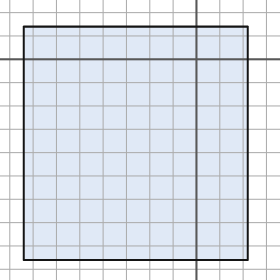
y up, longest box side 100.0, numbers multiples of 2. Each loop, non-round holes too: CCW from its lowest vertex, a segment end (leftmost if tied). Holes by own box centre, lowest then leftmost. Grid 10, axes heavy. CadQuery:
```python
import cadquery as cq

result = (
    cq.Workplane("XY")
    .moveTo(-74.0, -86.0)
    .lineTo(22.0, -86.0)
    .lineTo(22.0, 14.0)
    .lineTo(-74.0, 14.0)
    .close()
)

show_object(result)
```